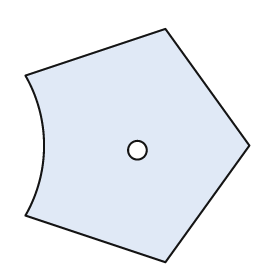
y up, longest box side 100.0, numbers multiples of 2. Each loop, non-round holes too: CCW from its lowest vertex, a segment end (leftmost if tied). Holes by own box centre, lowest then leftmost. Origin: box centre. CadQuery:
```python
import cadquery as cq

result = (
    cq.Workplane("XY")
    .moveTo(12.0, -50.0)
    .lineTo(48.0, 0.0)
    .lineTo(12.0, 50.0)
    .lineTo(-48.0, 30.0)
    .threePointArc((-40.0, 0.0), (-48.0, -30.0))
    .close()
    .moveTo(0.0, -2.0)
    .circle(4.0)
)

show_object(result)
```